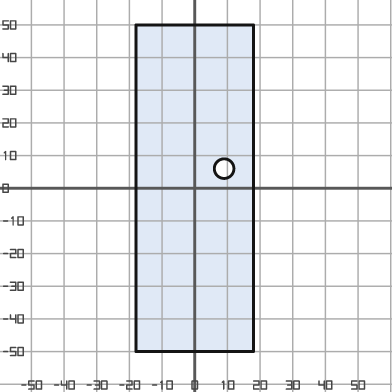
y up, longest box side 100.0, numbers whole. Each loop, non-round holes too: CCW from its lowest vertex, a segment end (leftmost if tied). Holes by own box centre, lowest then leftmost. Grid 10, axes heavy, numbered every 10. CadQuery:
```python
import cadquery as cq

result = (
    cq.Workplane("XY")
    .moveTo(-18.0, -50.0)
    .lineTo(18.0, -50.0)
    .lineTo(18.0, 50.0)
    .lineTo(-18.0, 50.0)
    .close()
    .moveTo(9.0, 6.0)
    .circle(3.0)
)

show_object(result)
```